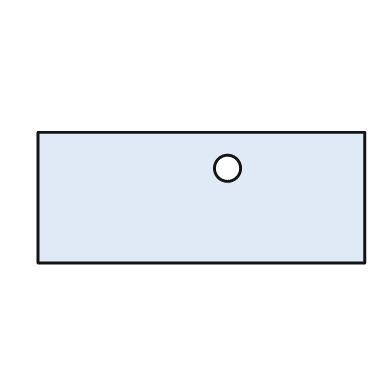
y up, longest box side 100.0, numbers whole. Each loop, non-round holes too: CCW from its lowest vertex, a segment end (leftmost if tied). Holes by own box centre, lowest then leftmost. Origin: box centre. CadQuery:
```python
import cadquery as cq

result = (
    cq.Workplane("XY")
    .moveTo(-50.0, -20.0)
    .lineTo(50.0, -20.0)
    .lineTo(50.0, 20.0)
    .lineTo(-50.0, 20.0)
    .close()
    .moveTo(8.0, 9.0)
    .circle(4.0)
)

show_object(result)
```